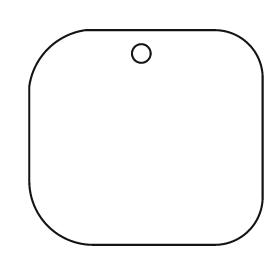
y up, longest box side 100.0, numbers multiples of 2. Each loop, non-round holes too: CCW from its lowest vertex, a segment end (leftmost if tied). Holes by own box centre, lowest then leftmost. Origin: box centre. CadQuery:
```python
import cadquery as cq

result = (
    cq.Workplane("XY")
    .moveTo(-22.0, -46.0)
    .lineTo(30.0, -46.0)
    .threePointArc((44.0, -40.0), (50.0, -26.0))
    .lineTo(50.0, 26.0)
    .threePointArc((44.0, 40.0), (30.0, 46.0))
    .lineTo(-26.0, 46.0)
    .threePointArc((-42.0, 38.0), (-50.0, 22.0))
    .lineTo(-50.0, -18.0)
    .threePointArc((-42.0, -38.0), (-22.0, -46.0))
    .close()
    .moveTo(-2.0, 36.0)
    .circle(4.0)
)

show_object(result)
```